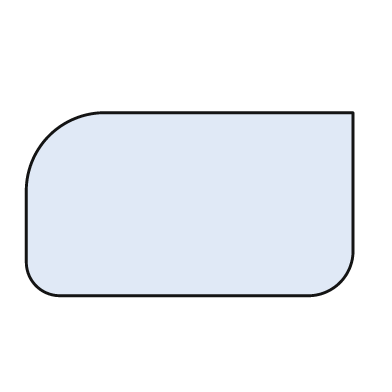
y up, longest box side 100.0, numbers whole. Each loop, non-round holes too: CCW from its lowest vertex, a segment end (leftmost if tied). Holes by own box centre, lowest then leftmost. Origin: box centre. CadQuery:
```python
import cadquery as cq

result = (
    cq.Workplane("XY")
    .moveTo(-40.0, -28.0)
    .lineTo(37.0, -28.0)
    .threePointArc((46.0, -24.0), (50.0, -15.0))
    .lineTo(50.0, 28.0)
    .lineTo(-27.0, 28.0)
    .threePointArc((-43.0, 21.0), (-50.0, 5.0))
    .lineTo(-50.0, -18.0)
    .threePointArc((-47.0, -25.0), (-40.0, -28.0))
    .close()
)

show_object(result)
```